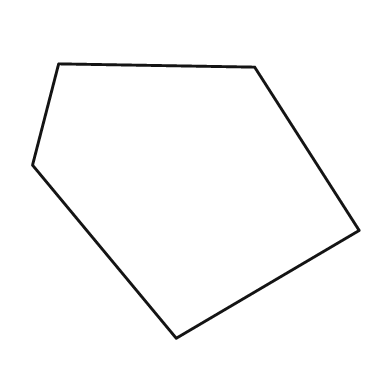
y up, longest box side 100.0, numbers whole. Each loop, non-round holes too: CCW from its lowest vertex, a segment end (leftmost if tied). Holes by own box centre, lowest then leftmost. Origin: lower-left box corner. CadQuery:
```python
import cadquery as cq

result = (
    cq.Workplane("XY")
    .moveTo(44.0, 0.0)
    .lineTo(100.0, 33.0)
    .lineTo(68.0, 83.0)
    .lineTo(8.0, 84.0)
    .lineTo(0.0, 53.0)
    .close()
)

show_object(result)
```